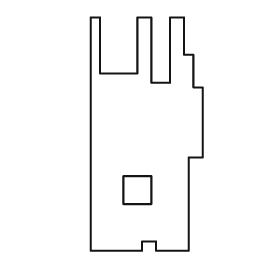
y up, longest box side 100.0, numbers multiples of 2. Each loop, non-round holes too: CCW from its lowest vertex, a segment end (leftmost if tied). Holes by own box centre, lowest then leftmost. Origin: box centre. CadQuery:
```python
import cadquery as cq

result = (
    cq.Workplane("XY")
    .moveTo(-24.0, -50.0)
    .lineTo(-2.0, -50.0)
    .lineTo(-2.0, -46.0)
    .lineTo(4.0, -46.0)
    .lineTo(4.0, -50.0)
    .lineTo(18.0, -50.0)
    .lineTo(18.0, -10.0)
    .lineTo(24.0, -10.0)
    .lineTo(24.0, 20.0)
    .lineTo(20.0, 20.0)
    .lineTo(20.0, 34.0)
    .lineTo(16.0, 34.0)
    .lineTo(16.0, 50.0)
    .lineTo(10.0, 50.0)
    .lineTo(10.0, 22.0)
    .lineTo(2.0, 22.0)
    .lineTo(2.0, 50.0)
    .lineTo(-4.0, 50.0)
    .lineTo(-4.0, 26.0)
    .lineTo(-20.0, 26.0)
    .lineTo(-20.0, 50.0)
    .lineTo(-24.0, 50.0)
    .close()
    .moveTo(-10.0, -30.0)
    .lineTo(2.0, -30.0)
    .lineTo(2.0, -18.0)
    .lineTo(-10.0, -18.0)
    .close()
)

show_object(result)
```